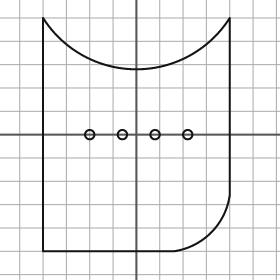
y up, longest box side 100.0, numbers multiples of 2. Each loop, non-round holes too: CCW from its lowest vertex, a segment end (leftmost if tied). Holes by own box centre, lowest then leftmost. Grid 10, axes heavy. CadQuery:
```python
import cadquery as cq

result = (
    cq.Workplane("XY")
    .moveTo(-40.0, -50.0)
    .lineTo(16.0, -50.0)
    .threePointArc((32.0, -42.0), (40.0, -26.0))
    .lineTo(40.0, 50.0)
    .threePointArc((0.0, 28.0), (-40.0, 50.0))
    .close()
    .moveTo(-20.0, 0.0)
    .circle(2.0)
    .moveTo(-6.0, 0.0)
    .circle(2.0)
    .moveTo(8.0, 0.0)
    .circle(2.0)
    .moveTo(22.0, 0.0)
    .circle(2.0)
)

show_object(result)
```